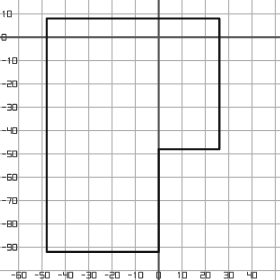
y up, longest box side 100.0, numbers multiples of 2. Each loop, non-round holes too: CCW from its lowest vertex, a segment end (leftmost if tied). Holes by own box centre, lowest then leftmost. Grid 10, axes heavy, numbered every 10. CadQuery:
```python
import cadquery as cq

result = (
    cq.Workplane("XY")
    .moveTo(-48.0, -92.0)
    .lineTo(0.0, -92.0)
    .lineTo(0.0, -48.0)
    .lineTo(26.0, -48.0)
    .lineTo(26.0, 8.0)
    .lineTo(-48.0, 8.0)
    .close()
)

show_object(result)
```